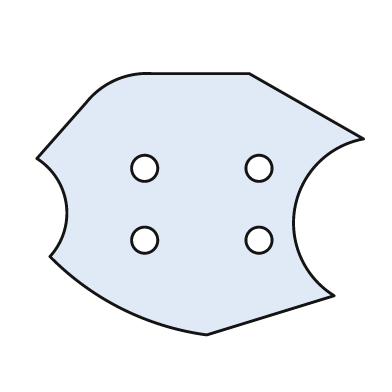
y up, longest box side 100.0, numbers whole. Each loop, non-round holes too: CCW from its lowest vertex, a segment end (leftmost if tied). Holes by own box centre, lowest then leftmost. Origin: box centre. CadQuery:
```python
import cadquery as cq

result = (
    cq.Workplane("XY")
    .moveTo(2.0, -40.0)
    .lineTo(41.0, -28.0)
    .threePointArc((29.0, -1.0), (50.0, 20.0))
    .lineTo(15.0, 40.0)
    .lineTo(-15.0, 40.0)
    .threePointArc((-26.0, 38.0), (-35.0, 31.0))
    .lineTo(-50.0, 14.0)
    .threePointArc((-41.0, 0.0), (-46.0, -16.0))
    .threePointArc((-24.0, -32.0), (2.0, -40.0))
    .close()
    .moveTo(-17.0, -11.0)
    .circle(4.0)
    .moveTo(18.0, -11.0)
    .circle(4.0)
    .moveTo(-17.0, 11.0)
    .circle(4.0)
    .moveTo(18.0, 11.0)
    .circle(4.0)
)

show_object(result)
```